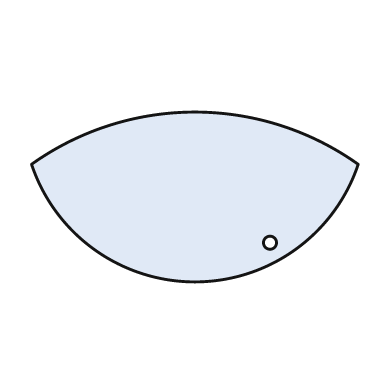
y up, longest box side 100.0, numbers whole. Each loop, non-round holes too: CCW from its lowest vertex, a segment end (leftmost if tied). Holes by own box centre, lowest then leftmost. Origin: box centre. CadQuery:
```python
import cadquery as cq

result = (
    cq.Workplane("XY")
    .moveTo(-50.0, 10.0)
    .threePointArc((0.0, -26.0), (50.0, 10.0))
    .threePointArc((0.0, 26.0), (-50.0, 10.0))
    .close()
    .moveTo(23.0, -14.0)
    .circle(2.0)
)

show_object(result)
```